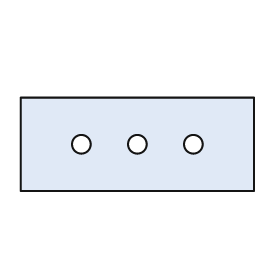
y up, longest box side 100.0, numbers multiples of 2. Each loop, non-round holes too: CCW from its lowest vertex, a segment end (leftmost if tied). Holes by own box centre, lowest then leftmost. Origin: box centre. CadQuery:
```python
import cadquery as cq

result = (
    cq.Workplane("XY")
    .moveTo(-50.0, -20.0)
    .lineTo(50.0, -20.0)
    .lineTo(50.0, 20.0)
    .lineTo(-50.0, 20.0)
    .close()
    .moveTo(-24.0, 0.0)
    .circle(4.0)
    .moveTo(0.0, 0.0)
    .circle(4.0)
    .moveTo(24.0, 0.0)
    .circle(4.0)
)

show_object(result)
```